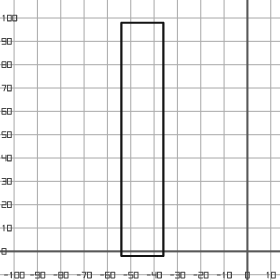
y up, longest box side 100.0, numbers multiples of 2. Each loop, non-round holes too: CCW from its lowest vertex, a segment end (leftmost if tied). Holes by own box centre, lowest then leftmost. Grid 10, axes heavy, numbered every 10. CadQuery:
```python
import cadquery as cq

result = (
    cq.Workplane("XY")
    .moveTo(-54.0, -2.0)
    .lineTo(-36.0, -2.0)
    .lineTo(-36.0, 98.0)
    .lineTo(-54.0, 98.0)
    .close()
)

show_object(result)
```